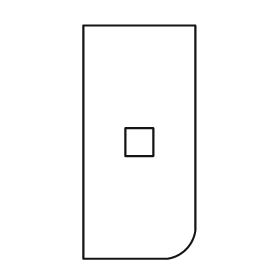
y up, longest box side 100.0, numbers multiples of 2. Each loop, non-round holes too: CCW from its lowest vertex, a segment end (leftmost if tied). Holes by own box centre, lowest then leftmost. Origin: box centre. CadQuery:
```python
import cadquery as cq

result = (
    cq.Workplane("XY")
    .moveTo(-24.0, -50.0)
    .lineTo(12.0, -50.0)
    .threePointArc((20.0, -46.0), (24.0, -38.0))
    .lineTo(24.0, 50.0)
    .lineTo(-24.0, 50.0)
    .close()
    .moveTo(-6.0, -6.0)
    .lineTo(6.0, -6.0)
    .lineTo(6.0, 6.0)
    .lineTo(-6.0, 6.0)
    .close()
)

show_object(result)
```